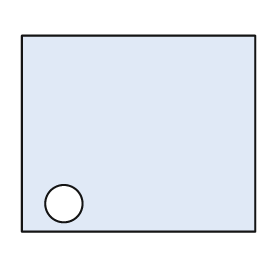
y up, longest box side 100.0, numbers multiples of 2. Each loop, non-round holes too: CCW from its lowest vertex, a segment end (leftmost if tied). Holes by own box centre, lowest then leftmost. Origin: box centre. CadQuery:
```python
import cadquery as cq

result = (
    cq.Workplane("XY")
    .moveTo(-50.0, -42.0)
    .lineTo(50.0, -42.0)
    .lineTo(50.0, 42.0)
    .lineTo(-50.0, 42.0)
    .close()
    .moveTo(-32.0, -30.0)
    .circle(8.0)
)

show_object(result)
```